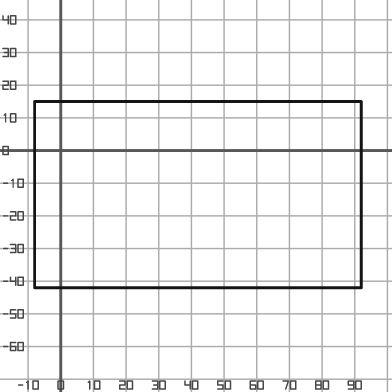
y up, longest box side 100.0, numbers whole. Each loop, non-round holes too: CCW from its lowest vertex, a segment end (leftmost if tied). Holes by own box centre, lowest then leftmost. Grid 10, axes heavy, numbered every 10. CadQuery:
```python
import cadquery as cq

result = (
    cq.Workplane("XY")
    .moveTo(-8.0, -42.0)
    .lineTo(92.0, -42.0)
    .lineTo(92.0, 15.0)
    .lineTo(-8.0, 15.0)
    .close()
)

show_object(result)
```